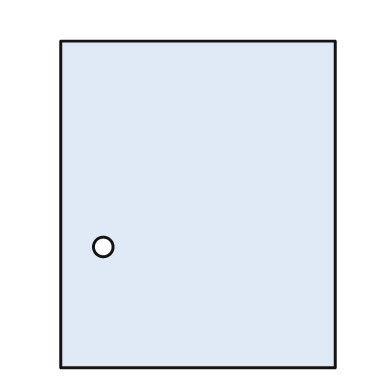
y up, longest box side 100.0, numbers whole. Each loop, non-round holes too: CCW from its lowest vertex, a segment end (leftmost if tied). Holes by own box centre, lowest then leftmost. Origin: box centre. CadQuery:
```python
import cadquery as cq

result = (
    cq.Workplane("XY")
    .moveTo(-42.0, -50.0)
    .lineTo(42.0, -50.0)
    .lineTo(42.0, 50.0)
    .lineTo(-42.0, 50.0)
    .close()
    .moveTo(-29.0, -13.0)
    .circle(3.0)
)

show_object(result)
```